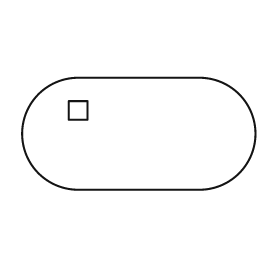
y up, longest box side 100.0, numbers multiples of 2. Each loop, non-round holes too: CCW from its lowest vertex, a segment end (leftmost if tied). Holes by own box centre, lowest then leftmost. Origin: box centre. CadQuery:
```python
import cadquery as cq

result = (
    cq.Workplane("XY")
    .moveTo(-26.0, -24.0)
    .lineTo(26.0, -24.0)
    .threePointArc((50.0, 0.0), (26.0, 24.0))
    .lineTo(-26.0, 24.0)
    .threePointArc((-50.0, 0.0), (-26.0, -24.0))
    .close()
    .moveTo(-30.0, 6.0)
    .lineTo(-22.0, 6.0)
    .lineTo(-22.0, 14.0)
    .lineTo(-30.0, 14.0)
    .close()
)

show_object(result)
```